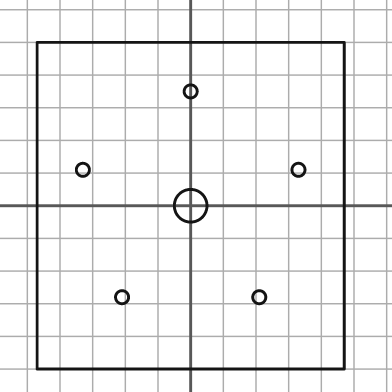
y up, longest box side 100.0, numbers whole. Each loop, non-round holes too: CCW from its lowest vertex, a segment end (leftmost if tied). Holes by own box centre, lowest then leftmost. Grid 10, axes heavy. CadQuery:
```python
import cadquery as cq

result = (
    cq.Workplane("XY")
    .moveTo(-47.0, -50.0)
    .lineTo(47.0, -50.0)
    .lineTo(47.0, 50.0)
    .lineTo(-47.0, 50.0)
    .close()
    .moveTo(-21.0, -28.0)
    .circle(2.0)
    .moveTo(21.0, -28.0)
    .circle(2.0)
    .moveTo(0.0, 0.0)
    .circle(5.0)
    .moveTo(-33.0, 11.0)
    .circle(2.0)
    .moveTo(33.0, 11.0)
    .circle(2.0)
    .moveTo(0.0, 35.0)
    .circle(2.0)
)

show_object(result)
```